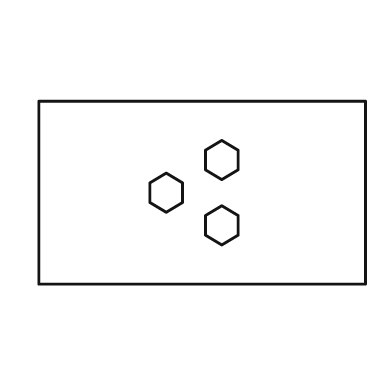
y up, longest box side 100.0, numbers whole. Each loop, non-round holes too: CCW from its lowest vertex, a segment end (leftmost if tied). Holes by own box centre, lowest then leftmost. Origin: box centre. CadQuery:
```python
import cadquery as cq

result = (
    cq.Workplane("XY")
    .moveTo(-50.0, -28.0)
    .lineTo(50.0, -28.0)
    .lineTo(50.0, 28.0)
    .lineTo(-50.0, 28.0)
    .close()
    .moveTo(6.0, -16.0)
    .lineTo(11.0, -13.0)
    .lineTo(11.0, -7.0)
    .lineTo(6.0, -4.0)
    .lineTo(1.0, -7.0)
    .lineTo(1.0, -13.0)
    .close()
    .moveTo(-11.0, -6.0)
    .lineTo(-6.0, -3.0)
    .lineTo(-6.0, 3.0)
    .lineTo(-11.0, 6.0)
    .lineTo(-16.0, 3.0)
    .lineTo(-16.0, -3.0)
    .close()
    .moveTo(6.0, 4.0)
    .lineTo(11.0, 7.0)
    .lineTo(11.0, 13.0)
    .lineTo(6.0, 16.0)
    .lineTo(1.0, 13.0)
    .lineTo(1.0, 7.0)
    .close()
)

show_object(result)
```